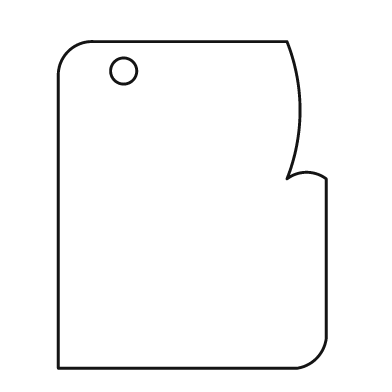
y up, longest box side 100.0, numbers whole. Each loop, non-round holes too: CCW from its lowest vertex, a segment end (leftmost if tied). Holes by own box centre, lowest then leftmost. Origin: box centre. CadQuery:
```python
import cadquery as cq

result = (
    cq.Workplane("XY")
    .moveTo(-41.0, -50.0)
    .lineTo(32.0, -50.0)
    .threePointArc((38.0, -47.0), (41.0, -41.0))
    .lineTo(41.0, 8.0)
    .threePointArc((35.0, 10.0), (29.0, 8.0))
    .threePointArc((33.0, 29.0), (29.0, 50.0))
    .lineTo(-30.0, 50.0)
    .threePointArc((-38.0, 47.0), (-41.0, 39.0))
    .close()
    .moveTo(-21.0, 41.0)
    .circle(4.0)
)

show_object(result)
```